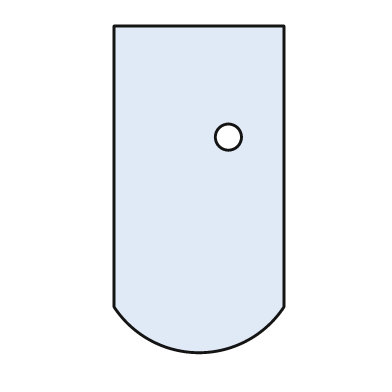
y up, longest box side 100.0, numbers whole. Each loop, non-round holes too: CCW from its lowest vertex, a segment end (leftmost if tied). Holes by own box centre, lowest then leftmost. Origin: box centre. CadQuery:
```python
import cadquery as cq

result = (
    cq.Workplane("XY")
    .moveTo(-26.0, -36.0)
    .threePointArc((0.0, -50.0), (26.0, -36.0))
    .lineTo(26.0, 50.0)
    .lineTo(-26.0, 50.0)
    .close()
    .moveTo(9.0, 16.0)
    .circle(4.0)
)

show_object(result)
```